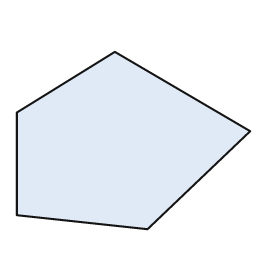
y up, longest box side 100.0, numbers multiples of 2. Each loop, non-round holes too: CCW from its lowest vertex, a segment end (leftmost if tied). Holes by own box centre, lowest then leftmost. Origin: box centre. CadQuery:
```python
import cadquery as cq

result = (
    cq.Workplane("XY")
    .moveTo(6.0, -38.0)
    .lineTo(50.0, 4.0)
    .lineTo(-8.0, 38.0)
    .lineTo(-50.0, 12.0)
    .lineTo(-50.0, -32.0)
    .close()
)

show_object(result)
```